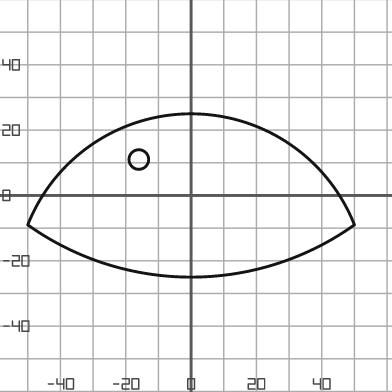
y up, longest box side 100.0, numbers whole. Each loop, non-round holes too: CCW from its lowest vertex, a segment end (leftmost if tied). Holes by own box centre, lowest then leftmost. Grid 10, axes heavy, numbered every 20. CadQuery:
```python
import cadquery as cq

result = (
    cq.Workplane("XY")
    .moveTo(-50.0, -9.0)
    .threePointArc((0.0, -25.0), (50.0, -9.0))
    .threePointArc((0.0, 25.0), (-50.0, -9.0))
    .close()
    .moveTo(-16.0, 11.0)
    .circle(3.0)
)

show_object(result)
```